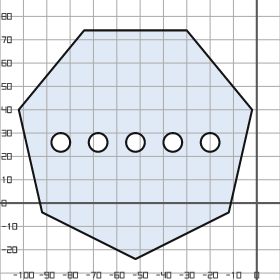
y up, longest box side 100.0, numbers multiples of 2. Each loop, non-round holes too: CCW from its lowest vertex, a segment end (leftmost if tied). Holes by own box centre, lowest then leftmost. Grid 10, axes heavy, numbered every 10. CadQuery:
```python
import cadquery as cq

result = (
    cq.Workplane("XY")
    .moveTo(-52.0, -24.0)
    .lineTo(-12.0, -4.0)
    .lineTo(-2.0, 40.0)
    .lineTo(-30.0, 74.0)
    .lineTo(-74.0, 74.0)
    .lineTo(-102.0, 40.0)
    .lineTo(-92.0, -4.0)
    .close()
    .moveTo(-84.0, 26.0)
    .circle(4.0)
    .moveTo(-68.0, 26.0)
    .circle(4.0)
    .moveTo(-52.0, 26.0)
    .circle(4.0)
    .moveTo(-36.0, 26.0)
    .circle(4.0)
    .moveTo(-20.0, 26.0)
    .circle(4.0)
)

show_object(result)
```